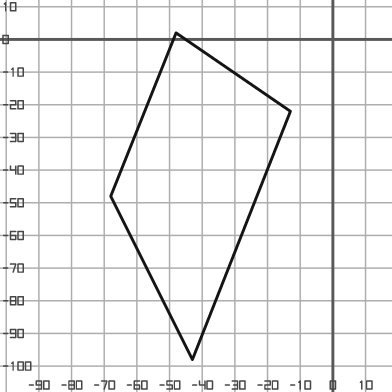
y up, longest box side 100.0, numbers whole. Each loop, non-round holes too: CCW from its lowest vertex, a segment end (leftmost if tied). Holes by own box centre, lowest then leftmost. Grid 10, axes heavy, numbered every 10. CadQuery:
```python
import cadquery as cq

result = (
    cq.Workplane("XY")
    .moveTo(-43.0, -98.0)
    .lineTo(-13.0, -22.0)
    .lineTo(-48.0, 2.0)
    .lineTo(-68.0, -48.0)
    .close()
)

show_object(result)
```